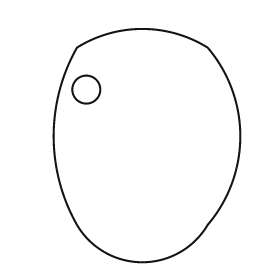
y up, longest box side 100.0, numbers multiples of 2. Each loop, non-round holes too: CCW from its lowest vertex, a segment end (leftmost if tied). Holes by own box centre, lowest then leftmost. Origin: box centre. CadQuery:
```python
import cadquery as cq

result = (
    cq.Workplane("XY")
    .moveTo(-30.0, -34.0)
    .threePointArc((-2.0, -50.0), (26.0, -34.0))
    .threePointArc((40.0, 4.0), (26.0, 42.0))
    .threePointArc((-2.0, 50.0), (-30.0, 42.0))
    .threePointArc((-40.0, 4.0), (-30.0, -34.0))
    .close()
    .moveTo(-26.0, 24.0)
    .circle(6.0)
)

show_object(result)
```